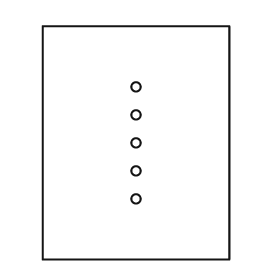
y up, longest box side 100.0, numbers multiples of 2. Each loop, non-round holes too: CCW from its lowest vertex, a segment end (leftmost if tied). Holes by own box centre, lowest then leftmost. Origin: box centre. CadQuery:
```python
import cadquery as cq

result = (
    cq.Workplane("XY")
    .moveTo(-40.0, -50.0)
    .lineTo(40.0, -50.0)
    .lineTo(40.0, 50.0)
    .lineTo(-40.0, 50.0)
    .close()
    .moveTo(0.0, -24.0)
    .circle(2.0)
    .moveTo(0.0, -12.0)
    .circle(2.0)
    .moveTo(0.0, 0.0)
    .circle(2.0)
    .moveTo(0.0, 12.0)
    .circle(2.0)
    .moveTo(0.0, 24.0)
    .circle(2.0)
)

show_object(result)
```